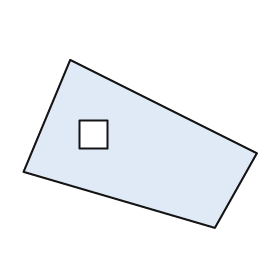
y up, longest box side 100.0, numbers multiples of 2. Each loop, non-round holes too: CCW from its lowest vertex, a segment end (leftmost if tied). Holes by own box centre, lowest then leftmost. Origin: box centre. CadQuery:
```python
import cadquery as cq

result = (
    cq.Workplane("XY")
    .moveTo(32.0, -36.0)
    .lineTo(50.0, -4.0)
    .lineTo(-30.0, 36.0)
    .lineTo(-50.0, -12.0)
    .close()
    .moveTo(-26.0, -2.0)
    .lineTo(-14.0, -2.0)
    .lineTo(-14.0, 10.0)
    .lineTo(-26.0, 10.0)
    .close()
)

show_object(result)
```